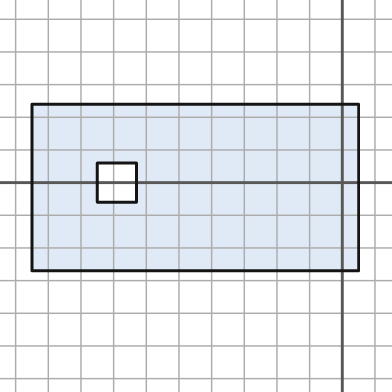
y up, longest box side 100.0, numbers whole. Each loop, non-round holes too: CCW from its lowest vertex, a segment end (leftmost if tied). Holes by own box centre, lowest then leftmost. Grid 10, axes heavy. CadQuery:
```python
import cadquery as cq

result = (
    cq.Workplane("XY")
    .moveTo(-95.0, -27.0)
    .lineTo(5.0, -27.0)
    .lineTo(5.0, 24.0)
    .lineTo(-95.0, 24.0)
    .close()
    .moveTo(-75.0, -6.0)
    .lineTo(-63.0, -6.0)
    .lineTo(-63.0, 6.0)
    .lineTo(-75.0, 6.0)
    .close()
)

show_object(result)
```